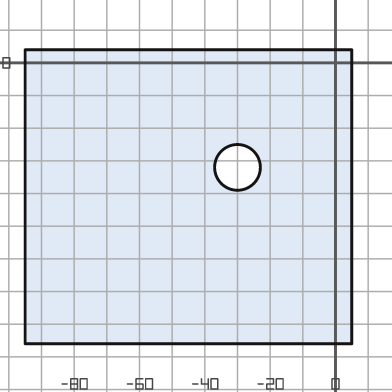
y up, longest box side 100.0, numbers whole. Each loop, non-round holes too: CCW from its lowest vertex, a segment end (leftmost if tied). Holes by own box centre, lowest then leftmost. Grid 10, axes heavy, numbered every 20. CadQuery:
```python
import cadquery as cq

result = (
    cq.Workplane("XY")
    .moveTo(-95.0, -86.0)
    .lineTo(5.0, -86.0)
    .lineTo(5.0, 4.0)
    .lineTo(-95.0, 4.0)
    .close()
    .moveTo(-30.0, -32.0)
    .circle(7.0)
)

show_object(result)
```